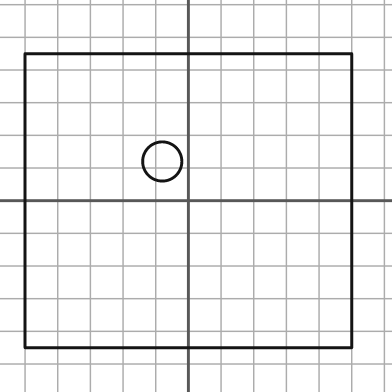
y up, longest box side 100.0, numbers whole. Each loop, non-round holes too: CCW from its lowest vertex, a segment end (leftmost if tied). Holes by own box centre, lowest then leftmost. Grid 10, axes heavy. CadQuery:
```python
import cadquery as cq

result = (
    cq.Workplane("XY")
    .moveTo(-50.0, -45.0)
    .lineTo(50.0, -45.0)
    .lineTo(50.0, 45.0)
    .lineTo(-50.0, 45.0)
    .close()
    .moveTo(-8.0, 12.0)
    .circle(6.0)
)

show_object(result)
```